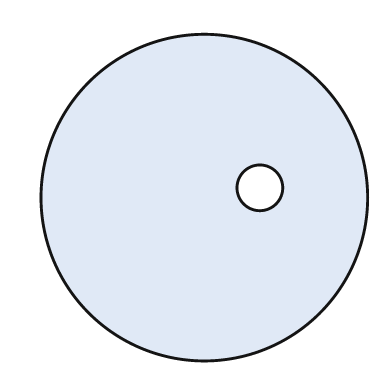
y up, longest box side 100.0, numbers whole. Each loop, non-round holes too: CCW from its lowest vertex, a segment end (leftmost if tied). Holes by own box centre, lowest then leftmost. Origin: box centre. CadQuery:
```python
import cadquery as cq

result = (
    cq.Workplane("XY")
    .moveTo(0.0, 0.0)
    .circle(50.0)
    .moveTo(17.0, 3.0)
    .circle(7.0)
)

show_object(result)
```